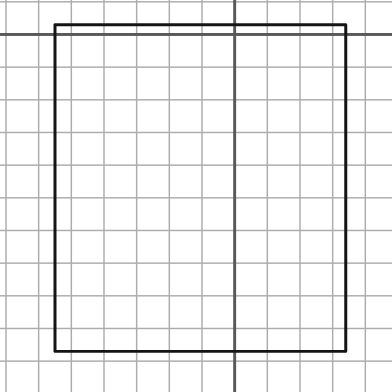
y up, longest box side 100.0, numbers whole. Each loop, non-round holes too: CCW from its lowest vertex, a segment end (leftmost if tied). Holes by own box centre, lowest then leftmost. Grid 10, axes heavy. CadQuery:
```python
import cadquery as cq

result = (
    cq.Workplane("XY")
    .moveTo(-55.0, -97.0)
    .lineTo(34.0, -97.0)
    .lineTo(34.0, 3.0)
    .lineTo(-55.0, 3.0)
    .close()
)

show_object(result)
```